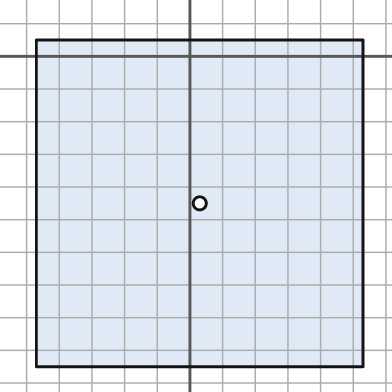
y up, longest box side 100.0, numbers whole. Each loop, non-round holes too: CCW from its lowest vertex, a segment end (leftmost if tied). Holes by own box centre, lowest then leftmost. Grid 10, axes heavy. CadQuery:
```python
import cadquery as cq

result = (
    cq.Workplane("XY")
    .moveTo(-47.0, -95.0)
    .lineTo(53.0, -95.0)
    .lineTo(53.0, 5.0)
    .lineTo(-47.0, 5.0)
    .close()
    .moveTo(3.0, -45.0)
    .circle(2.0)
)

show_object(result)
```